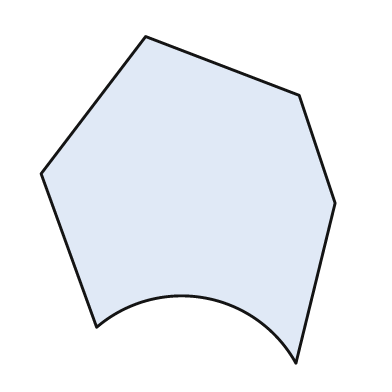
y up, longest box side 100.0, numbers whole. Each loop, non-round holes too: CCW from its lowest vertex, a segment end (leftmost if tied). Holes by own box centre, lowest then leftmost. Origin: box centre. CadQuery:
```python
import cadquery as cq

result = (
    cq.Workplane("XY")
    .moveTo(33.0, -50.0)
    .lineTo(45.0, -1.0)
    .lineTo(34.0, 32.0)
    .lineTo(-13.0, 50.0)
    .lineTo(-45.0, 8.0)
    .lineTo(-28.0, -39.0)
    .threePointArc((5.0, -30.0), (33.0, -50.0))
    .close()
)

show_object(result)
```